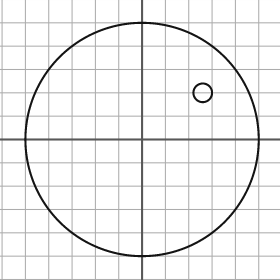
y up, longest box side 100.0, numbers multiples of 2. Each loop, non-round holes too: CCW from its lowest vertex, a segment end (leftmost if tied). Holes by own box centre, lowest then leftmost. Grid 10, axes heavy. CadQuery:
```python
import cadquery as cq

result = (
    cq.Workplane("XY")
    .moveTo(0.0, 0.0)
    .circle(50.0)
    .moveTo(26.0, 20.0)
    .circle(4.0)
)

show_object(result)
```